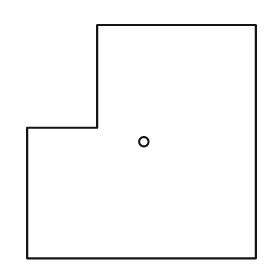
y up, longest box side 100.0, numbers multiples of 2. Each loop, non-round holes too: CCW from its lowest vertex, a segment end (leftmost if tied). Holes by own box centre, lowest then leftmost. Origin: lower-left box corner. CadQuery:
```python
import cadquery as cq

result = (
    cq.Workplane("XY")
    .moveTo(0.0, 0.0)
    .lineTo(98.0, 0.0)
    .lineTo(98.0, 100.0)
    .lineTo(30.0, 100.0)
    .lineTo(30.0, 56.0)
    .lineTo(0.0, 56.0)
    .close()
    .moveTo(50.0, 50.0)
    .circle(2.0)
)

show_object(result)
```